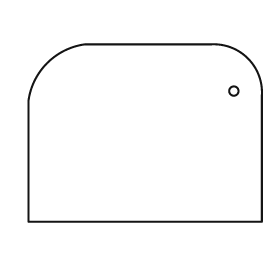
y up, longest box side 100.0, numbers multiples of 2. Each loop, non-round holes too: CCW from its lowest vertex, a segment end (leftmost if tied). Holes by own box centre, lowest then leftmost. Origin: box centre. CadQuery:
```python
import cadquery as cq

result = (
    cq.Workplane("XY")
    .moveTo(-50.0, -38.0)
    .lineTo(50.0, -38.0)
    .lineTo(50.0, 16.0)
    .threePointArc((44.0, 32.0), (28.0, 38.0))
    .lineTo(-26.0, 38.0)
    .threePointArc((-42.0, 30.0), (-50.0, 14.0))
    .close()
    .moveTo(38.0, 18.0)
    .circle(2.0)
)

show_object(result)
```